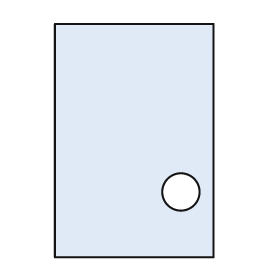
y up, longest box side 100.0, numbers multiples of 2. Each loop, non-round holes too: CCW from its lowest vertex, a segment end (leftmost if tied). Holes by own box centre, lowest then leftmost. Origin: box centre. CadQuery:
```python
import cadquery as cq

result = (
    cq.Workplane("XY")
    .moveTo(-34.0, -50.0)
    .lineTo(34.0, -50.0)
    .lineTo(34.0, 50.0)
    .lineTo(-34.0, 50.0)
    .close()
    .moveTo(20.0, -22.0)
    .circle(8.0)
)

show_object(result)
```